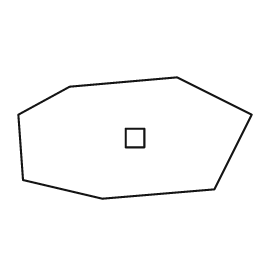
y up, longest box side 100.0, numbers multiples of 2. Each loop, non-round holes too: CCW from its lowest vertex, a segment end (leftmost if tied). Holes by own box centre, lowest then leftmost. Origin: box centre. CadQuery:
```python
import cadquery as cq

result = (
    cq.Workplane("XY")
    .moveTo(-14.0, -26.0)
    .lineTo(34.0, -22.0)
    .lineTo(50.0, 10.0)
    .lineTo(18.0, 26.0)
    .lineTo(-28.0, 22.0)
    .lineTo(-50.0, 10.0)
    .lineTo(-48.0, -18.0)
    .close()
    .moveTo(-4.0, -4.0)
    .lineTo(4.0, -4.0)
    .lineTo(4.0, 4.0)
    .lineTo(-4.0, 4.0)
    .close()
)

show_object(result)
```